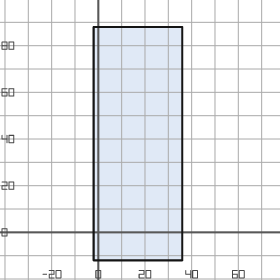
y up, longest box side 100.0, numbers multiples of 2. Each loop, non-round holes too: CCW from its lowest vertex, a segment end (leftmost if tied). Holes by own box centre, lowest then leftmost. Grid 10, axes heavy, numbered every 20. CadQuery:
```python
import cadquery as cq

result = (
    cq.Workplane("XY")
    .moveTo(-2.0, -12.0)
    .lineTo(36.0, -12.0)
    .lineTo(36.0, 88.0)
    .lineTo(-2.0, 88.0)
    .close()
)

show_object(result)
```